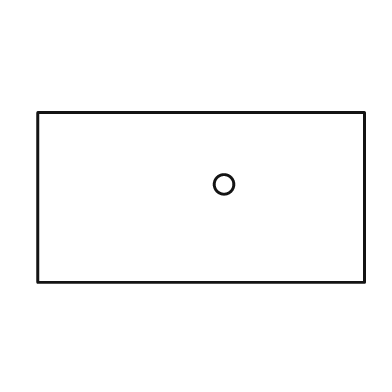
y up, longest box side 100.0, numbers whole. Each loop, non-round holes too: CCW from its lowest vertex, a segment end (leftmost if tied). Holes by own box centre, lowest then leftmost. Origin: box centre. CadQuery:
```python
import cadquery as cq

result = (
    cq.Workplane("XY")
    .moveTo(-50.0, -26.0)
    .lineTo(50.0, -26.0)
    .lineTo(50.0, 26.0)
    .lineTo(-50.0, 26.0)
    .close()
    .moveTo(7.0, 4.0)
    .circle(3.0)
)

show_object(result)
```